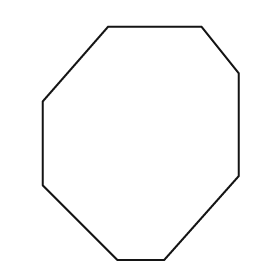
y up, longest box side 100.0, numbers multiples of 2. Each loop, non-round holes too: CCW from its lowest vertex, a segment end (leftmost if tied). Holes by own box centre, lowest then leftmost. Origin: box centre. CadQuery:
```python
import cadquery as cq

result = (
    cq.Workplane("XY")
    .moveTo(-10.0, -50.0)
    .lineTo(10.0, -50.0)
    .lineTo(42.0, -14.0)
    .lineTo(42.0, 30.0)
    .lineTo(26.0, 50.0)
    .lineTo(-14.0, 50.0)
    .lineTo(-42.0, 18.0)
    .lineTo(-42.0, -18.0)
    .close()
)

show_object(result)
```